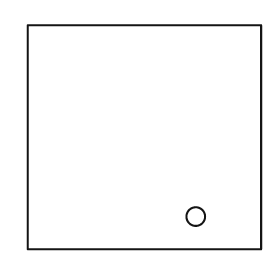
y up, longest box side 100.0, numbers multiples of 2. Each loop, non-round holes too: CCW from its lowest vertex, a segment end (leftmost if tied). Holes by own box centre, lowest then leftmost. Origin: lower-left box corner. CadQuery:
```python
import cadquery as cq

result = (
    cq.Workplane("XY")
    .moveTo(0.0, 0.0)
    .lineTo(100.0, 0.0)
    .lineTo(100.0, 96.0)
    .lineTo(0.0, 96.0)
    .close()
    .moveTo(72.0, 14.0)
    .circle(4.0)
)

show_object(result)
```